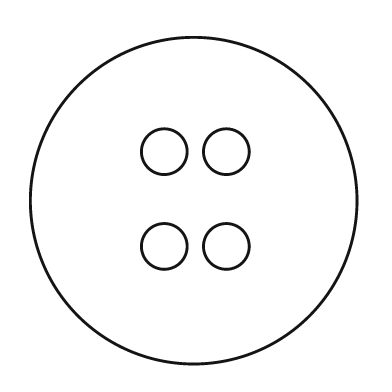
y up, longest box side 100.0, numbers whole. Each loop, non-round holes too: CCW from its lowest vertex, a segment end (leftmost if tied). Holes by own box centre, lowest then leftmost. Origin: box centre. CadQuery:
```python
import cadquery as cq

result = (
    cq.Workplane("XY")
    .moveTo(0.0, 0.0)
    .circle(50.0)
    .moveTo(-9.0, -14.0)
    .circle(7.0)
    .moveTo(10.0, -14.0)
    .circle(7.0)
    .moveTo(-9.0, 15.0)
    .circle(7.0)
    .moveTo(10.0, 15.0)
    .circle(7.0)
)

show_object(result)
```